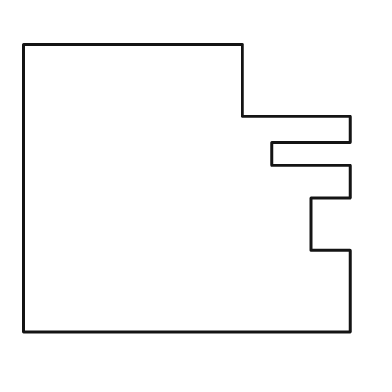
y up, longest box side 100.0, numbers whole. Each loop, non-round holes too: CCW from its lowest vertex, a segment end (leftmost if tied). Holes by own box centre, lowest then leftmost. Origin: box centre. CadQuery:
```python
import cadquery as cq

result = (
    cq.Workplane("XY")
    .moveTo(-50.0, -44.0)
    .lineTo(50.0, -44.0)
    .lineTo(50.0, -19.0)
    .lineTo(38.0, -19.0)
    .lineTo(38.0, -3.0)
    .lineTo(50.0, -3.0)
    .lineTo(50.0, 7.0)
    .lineTo(26.0, 7.0)
    .lineTo(26.0, 14.0)
    .lineTo(50.0, 14.0)
    .lineTo(50.0, 22.0)
    .lineTo(17.0, 22.0)
    .lineTo(17.0, 44.0)
    .lineTo(-50.0, 44.0)
    .close()
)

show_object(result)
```